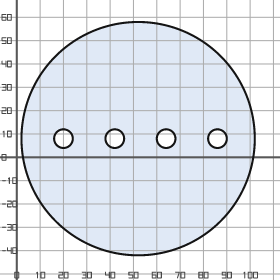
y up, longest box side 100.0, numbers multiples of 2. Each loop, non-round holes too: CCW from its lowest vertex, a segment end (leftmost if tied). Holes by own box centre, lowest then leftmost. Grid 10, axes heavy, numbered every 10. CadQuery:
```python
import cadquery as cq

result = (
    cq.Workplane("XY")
    .moveTo(52.0, 8.0)
    .circle(50.0)
    .moveTo(20.0, 8.0)
    .circle(4.0)
    .moveTo(42.0, 8.0)
    .circle(4.0)
    .moveTo(64.0, 8.0)
    .circle(4.0)
    .moveTo(86.0, 8.0)
    .circle(4.0)
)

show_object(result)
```